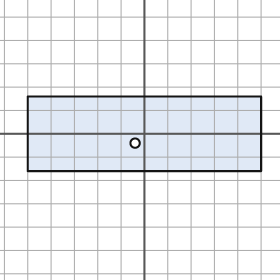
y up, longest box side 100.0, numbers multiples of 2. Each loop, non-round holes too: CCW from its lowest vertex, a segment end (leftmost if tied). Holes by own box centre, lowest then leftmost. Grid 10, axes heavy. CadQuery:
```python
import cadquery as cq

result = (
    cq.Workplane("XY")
    .moveTo(-50.0, -16.0)
    .lineTo(50.0, -16.0)
    .lineTo(50.0, 16.0)
    .lineTo(-50.0, 16.0)
    .close()
    .moveTo(-4.0, -4.0)
    .circle(2.0)
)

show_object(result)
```